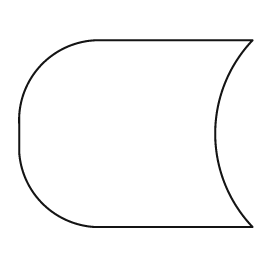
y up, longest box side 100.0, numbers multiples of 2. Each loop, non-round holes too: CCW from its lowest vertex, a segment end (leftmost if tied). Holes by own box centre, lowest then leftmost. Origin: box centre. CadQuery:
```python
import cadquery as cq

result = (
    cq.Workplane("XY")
    .moveTo(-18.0, -40.0)
    .lineTo(50.0, -40.0)
    .threePointArc((34.0, 0.0), (50.0, 40.0))
    .lineTo(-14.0, 40.0)
    .threePointArc((-40.0, 30.0), (-50.0, 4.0))
    .lineTo(-50.0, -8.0)
    .threePointArc((-40.0, -30.0), (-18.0, -40.0))
    .close()
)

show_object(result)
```